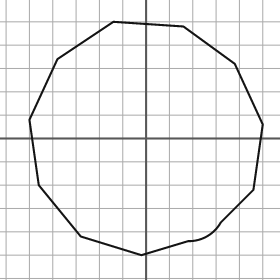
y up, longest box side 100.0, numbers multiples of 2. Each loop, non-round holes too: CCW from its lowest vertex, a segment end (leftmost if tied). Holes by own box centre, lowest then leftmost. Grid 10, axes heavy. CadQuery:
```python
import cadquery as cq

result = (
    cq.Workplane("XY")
    .moveTo(-2.0, -50.0)
    .lineTo(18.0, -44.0)
    .threePointArc((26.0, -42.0), (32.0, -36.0))
    .lineTo(46.0, -22.0)
    .lineTo(50.0, 6.0)
    .lineTo(38.0, 32.0)
    .lineTo(16.0, 48.0)
    .lineTo(-14.0, 50.0)
    .lineTo(-38.0, 34.0)
    .lineTo(-50.0, 8.0)
    .lineTo(-46.0, -20.0)
    .lineTo(-28.0, -42.0)
    .close()
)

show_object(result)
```